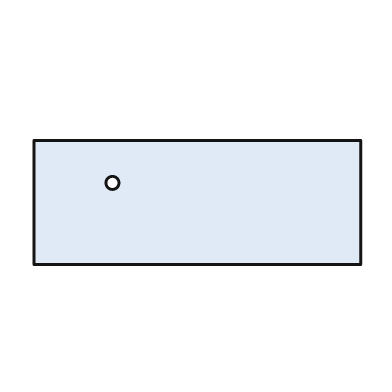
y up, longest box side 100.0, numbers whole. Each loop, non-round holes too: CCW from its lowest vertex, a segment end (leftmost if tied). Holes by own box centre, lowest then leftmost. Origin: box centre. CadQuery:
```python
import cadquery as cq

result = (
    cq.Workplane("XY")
    .moveTo(-50.0, -19.0)
    .lineTo(50.0, -19.0)
    .lineTo(50.0, 19.0)
    .lineTo(-50.0, 19.0)
    .close()
    .moveTo(-26.0, 6.0)
    .circle(2.0)
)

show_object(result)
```